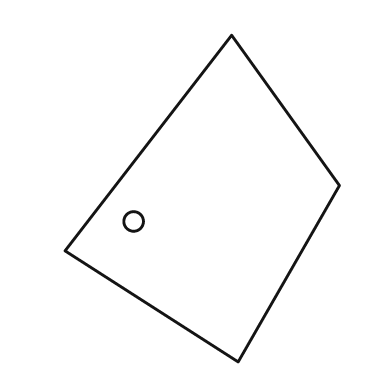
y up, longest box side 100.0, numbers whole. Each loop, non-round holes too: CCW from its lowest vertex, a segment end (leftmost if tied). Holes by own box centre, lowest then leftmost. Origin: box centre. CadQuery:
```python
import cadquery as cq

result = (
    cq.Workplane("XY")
    .moveTo(11.0, -50.0)
    .lineTo(42.0, 4.0)
    .lineTo(9.0, 50.0)
    .lineTo(-42.0, -16.0)
    .close()
    .moveTo(-21.0, -7.0)
    .circle(3.0)
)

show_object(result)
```